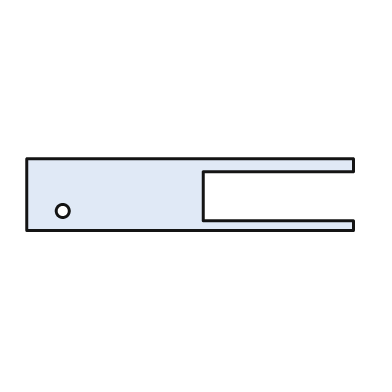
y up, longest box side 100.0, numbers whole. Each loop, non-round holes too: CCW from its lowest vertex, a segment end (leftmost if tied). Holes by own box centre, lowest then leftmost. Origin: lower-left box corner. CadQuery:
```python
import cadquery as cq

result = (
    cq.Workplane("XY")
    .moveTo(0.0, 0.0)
    .lineTo(100.0, 0.0)
    .lineTo(100.0, 3.0)
    .lineTo(54.0, 3.0)
    .lineTo(54.0, 18.0)
    .lineTo(100.0, 18.0)
    .lineTo(100.0, 22.0)
    .lineTo(0.0, 22.0)
    .close()
    .moveTo(11.0, 6.0)
    .circle(2.0)
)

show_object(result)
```